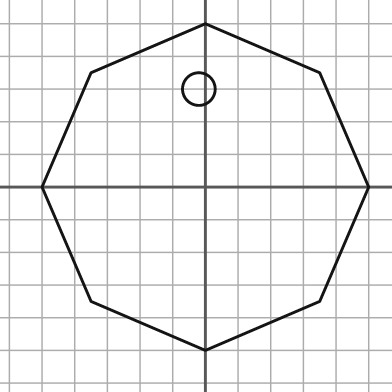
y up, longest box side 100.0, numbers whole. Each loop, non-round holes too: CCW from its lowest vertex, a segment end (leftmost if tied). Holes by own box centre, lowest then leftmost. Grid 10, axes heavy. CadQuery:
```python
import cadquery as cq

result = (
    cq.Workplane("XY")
    .moveTo(0.0, -50.0)
    .lineTo(35.0, -35.0)
    .lineTo(50.0, 0.0)
    .lineTo(35.0, 35.0)
    .lineTo(0.0, 50.0)
    .lineTo(-35.0, 35.0)
    .lineTo(-50.0, 0.0)
    .lineTo(-35.0, -35.0)
    .close()
    .moveTo(-2.0, 30.0)
    .circle(5.0)
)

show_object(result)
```